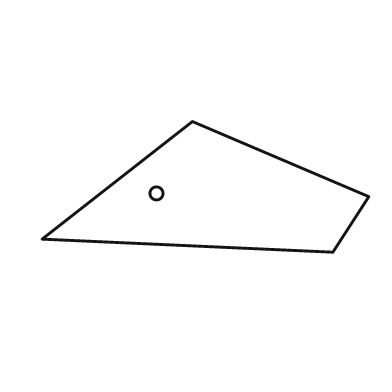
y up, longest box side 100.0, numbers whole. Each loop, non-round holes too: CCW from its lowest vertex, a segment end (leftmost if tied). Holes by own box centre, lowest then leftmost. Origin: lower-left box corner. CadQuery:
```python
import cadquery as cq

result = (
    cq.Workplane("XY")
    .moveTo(89.0, 0.0)
    .lineTo(100.0, 17.0)
    .lineTo(46.0, 40.0)
    .lineTo(0.0, 4.0)
    .close()
    .moveTo(35.0, 18.0)
    .circle(2.0)
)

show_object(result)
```